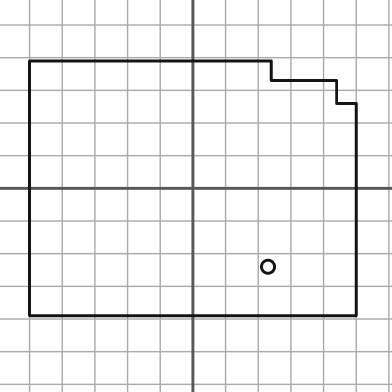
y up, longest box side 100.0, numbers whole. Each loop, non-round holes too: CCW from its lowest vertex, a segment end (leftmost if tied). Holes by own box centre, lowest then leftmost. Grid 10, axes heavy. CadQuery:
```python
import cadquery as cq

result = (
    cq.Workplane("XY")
    .moveTo(-50.0, -39.0)
    .lineTo(50.0, -39.0)
    .lineTo(50.0, 26.0)
    .lineTo(44.0, 26.0)
    .lineTo(44.0, 33.0)
    .lineTo(24.0, 33.0)
    .lineTo(24.0, 39.0)
    .lineTo(-50.0, 39.0)
    .close()
    .moveTo(23.0, -24.0)
    .circle(2.0)
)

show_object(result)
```